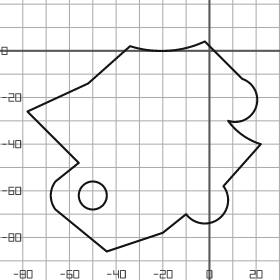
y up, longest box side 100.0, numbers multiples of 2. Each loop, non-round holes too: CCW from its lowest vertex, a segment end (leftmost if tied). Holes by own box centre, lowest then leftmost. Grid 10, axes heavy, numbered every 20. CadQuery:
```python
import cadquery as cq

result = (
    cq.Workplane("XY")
    .moveTo(-44.0, -86.0)
    .lineTo(-20.0, -78.0)
    .lineTo(-10.0, -70.0)
    .threePointArc((4.0, -72.0), (6.0, -58.0))
    .lineTo(22.0, -40.0)
    .threePointArc((14.0, -36.0), (8.0, -30.0))
    .threePointArc((20.0, -24.0), (14.0, -12.0))
    .lineTo(-2.0, 4.0)
    .threePointArc((-18.0, 0.0), (-34.0, 2.0))
    .lineTo(-52.0, -14.0)
    .lineTo(-78.0, -26.0)
    .lineTo(-56.0, -48.0)
    .lineTo(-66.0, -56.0)
    .threePointArc((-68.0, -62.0), (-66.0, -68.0))
    .close()
    .moveTo(-50.0, -62.0)
    .circle(6.0)
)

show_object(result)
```